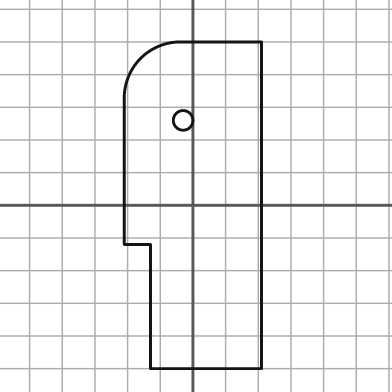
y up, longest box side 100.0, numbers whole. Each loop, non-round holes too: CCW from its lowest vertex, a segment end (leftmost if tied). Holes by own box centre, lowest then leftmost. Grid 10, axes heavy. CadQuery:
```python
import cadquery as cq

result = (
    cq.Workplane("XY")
    .moveTo(-13.0, -50.0)
    .lineTo(21.0, -50.0)
    .lineTo(21.0, 50.0)
    .lineTo(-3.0, 50.0)
    .threePointArc((-16.0, 45.0), (-21.0, 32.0))
    .lineTo(-21.0, -12.0)
    .lineTo(-13.0, -12.0)
    .close()
    .moveTo(-3.0, 26.0)
    .circle(3.0)
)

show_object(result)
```